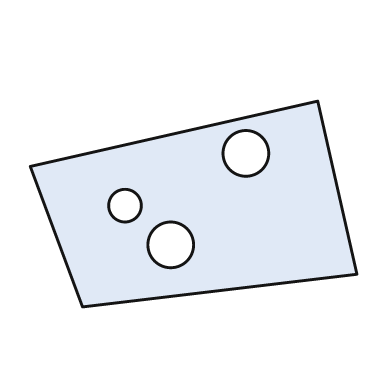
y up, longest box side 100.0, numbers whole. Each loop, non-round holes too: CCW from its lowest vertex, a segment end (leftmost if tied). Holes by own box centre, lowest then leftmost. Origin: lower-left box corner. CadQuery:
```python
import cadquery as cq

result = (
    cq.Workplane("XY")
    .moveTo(16.0, 0.0)
    .lineTo(100.0, 10.0)
    .lineTo(88.0, 63.0)
    .lineTo(0.0, 43.0)
    .close()
    .moveTo(43.0, 19.0)
    .circle(7.0)
    .moveTo(29.0, 31.0)
    .circle(5.0)
    .moveTo(66.0, 47.0)
    .circle(7.0)
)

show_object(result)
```